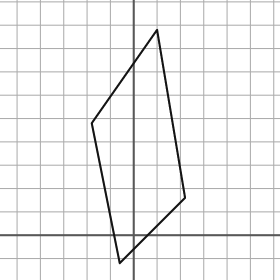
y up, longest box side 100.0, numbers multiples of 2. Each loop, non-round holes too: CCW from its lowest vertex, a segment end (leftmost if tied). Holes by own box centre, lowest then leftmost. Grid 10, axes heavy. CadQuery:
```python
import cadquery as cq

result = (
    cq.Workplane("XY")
    .moveTo(-6.0, -12.0)
    .lineTo(22.0, 16.0)
    .lineTo(10.0, 88.0)
    .lineTo(-18.0, 48.0)
    .close()
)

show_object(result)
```